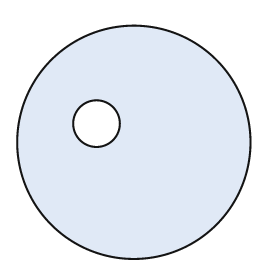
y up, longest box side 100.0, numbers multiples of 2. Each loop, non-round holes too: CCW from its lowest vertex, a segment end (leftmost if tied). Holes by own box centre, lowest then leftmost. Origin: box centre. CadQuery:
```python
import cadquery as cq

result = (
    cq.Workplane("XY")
    .moveTo(0.0, 0.0)
    .circle(50.0)
    .moveTo(-16.0, 8.0)
    .circle(10.0)
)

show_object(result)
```